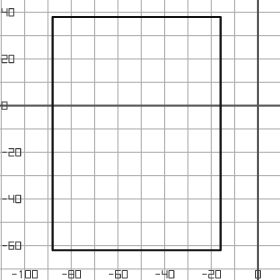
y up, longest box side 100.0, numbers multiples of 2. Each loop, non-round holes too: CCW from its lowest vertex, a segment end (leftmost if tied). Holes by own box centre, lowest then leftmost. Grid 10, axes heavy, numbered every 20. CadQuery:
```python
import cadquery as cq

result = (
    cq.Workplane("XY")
    .moveTo(-88.0, -62.0)
    .lineTo(-16.0, -62.0)
    .lineTo(-16.0, 38.0)
    .lineTo(-88.0, 38.0)
    .close()
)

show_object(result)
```